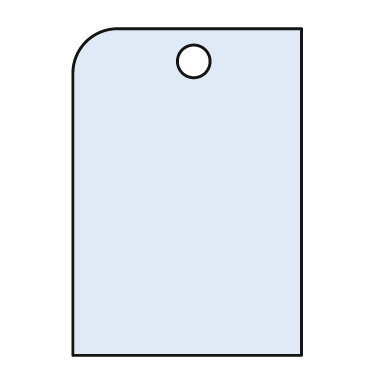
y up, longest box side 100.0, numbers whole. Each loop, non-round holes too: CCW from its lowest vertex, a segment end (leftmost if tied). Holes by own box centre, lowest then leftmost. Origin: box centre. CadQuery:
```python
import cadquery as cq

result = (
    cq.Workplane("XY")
    .moveTo(-35.0, -50.0)
    .lineTo(35.0, -50.0)
    .lineTo(35.0, 50.0)
    .lineTo(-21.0, 50.0)
    .threePointArc((-31.0, 46.0), (-35.0, 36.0))
    .close()
    .moveTo(2.0, 40.0)
    .circle(5.0)
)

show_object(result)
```